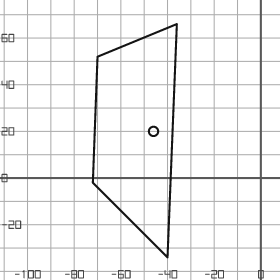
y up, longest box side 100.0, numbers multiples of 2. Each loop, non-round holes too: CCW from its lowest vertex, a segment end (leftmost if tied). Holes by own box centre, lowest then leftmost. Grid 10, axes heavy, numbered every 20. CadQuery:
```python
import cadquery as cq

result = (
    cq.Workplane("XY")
    .moveTo(-40.0, -34.0)
    .lineTo(-36.0, 66.0)
    .lineTo(-70.0, 52.0)
    .lineTo(-72.0, -2.0)
    .close()
    .moveTo(-46.0, 20.0)
    .circle(2.0)
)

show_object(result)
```